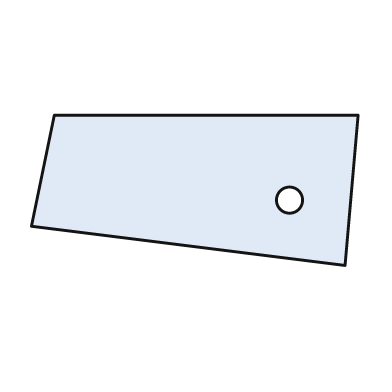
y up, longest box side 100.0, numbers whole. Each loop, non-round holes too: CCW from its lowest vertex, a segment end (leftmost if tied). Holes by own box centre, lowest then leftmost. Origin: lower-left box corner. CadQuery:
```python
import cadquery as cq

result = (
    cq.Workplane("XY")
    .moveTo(96.0, 0.0)
    .lineTo(100.0, 46.0)
    .lineTo(7.0, 46.0)
    .lineTo(0.0, 12.0)
    .close()
    .moveTo(79.0, 20.0)
    .circle(4.0)
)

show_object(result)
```